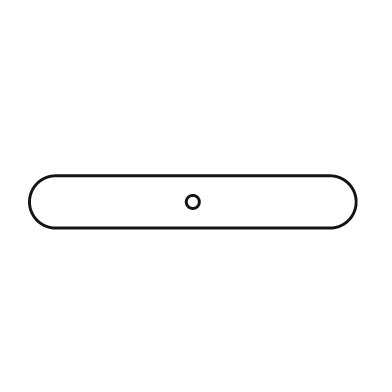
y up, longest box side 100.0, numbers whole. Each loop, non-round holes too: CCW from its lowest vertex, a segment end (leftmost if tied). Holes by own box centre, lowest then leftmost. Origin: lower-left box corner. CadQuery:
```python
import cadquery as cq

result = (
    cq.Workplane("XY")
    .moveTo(8.0, 0.0)
    .lineTo(92.0, 0.0)
    .threePointArc((100.0, 8.0), (92.0, 16.0))
    .lineTo(8.0, 16.0)
    .threePointArc((0.0, 8.0), (8.0, 0.0))
    .close()
    .moveTo(50.0, 8.0)
    .circle(2.0)
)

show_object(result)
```